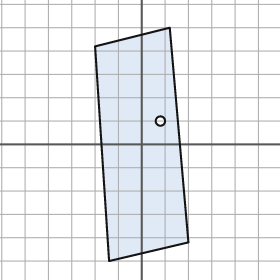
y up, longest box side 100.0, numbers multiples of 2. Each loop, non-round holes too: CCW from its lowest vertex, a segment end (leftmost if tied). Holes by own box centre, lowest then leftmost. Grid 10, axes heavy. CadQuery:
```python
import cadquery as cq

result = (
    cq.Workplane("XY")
    .moveTo(-14.0, -50.0)
    .lineTo(20.0, -42.0)
    .lineTo(12.0, 50.0)
    .lineTo(-20.0, 42.0)
    .close()
    .moveTo(8.0, 10.0)
    .circle(2.0)
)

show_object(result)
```